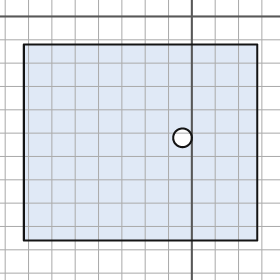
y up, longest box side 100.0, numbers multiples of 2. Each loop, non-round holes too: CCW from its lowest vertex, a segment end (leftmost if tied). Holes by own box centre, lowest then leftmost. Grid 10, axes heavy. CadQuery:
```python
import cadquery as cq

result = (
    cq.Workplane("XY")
    .moveTo(-72.0, -96.0)
    .lineTo(28.0, -96.0)
    .lineTo(28.0, -12.0)
    .lineTo(-72.0, -12.0)
    .close()
    .moveTo(-4.0, -52.0)
    .circle(4.0)
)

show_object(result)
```